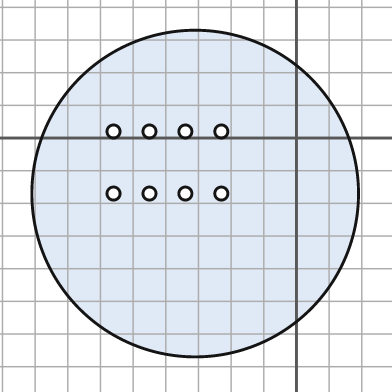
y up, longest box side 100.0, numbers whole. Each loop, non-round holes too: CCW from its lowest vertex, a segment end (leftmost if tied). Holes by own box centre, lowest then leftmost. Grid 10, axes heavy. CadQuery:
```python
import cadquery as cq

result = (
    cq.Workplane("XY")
    .moveTo(-31.0, -17.0)
    .circle(50.0)
    .moveTo(-56.0, -17.0)
    .circle(2.0)
    .moveTo(-45.0, -17.0)
    .circle(2.0)
    .moveTo(-34.0, -17.0)
    .circle(2.0)
    .moveTo(-23.0, -17.0)
    .circle(2.0)
    .moveTo(-56.0, 2.0)
    .circle(2.0)
    .moveTo(-45.0, 2.0)
    .circle(2.0)
    .moveTo(-34.0, 2.0)
    .circle(2.0)
    .moveTo(-23.0, 2.0)
    .circle(2.0)
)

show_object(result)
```